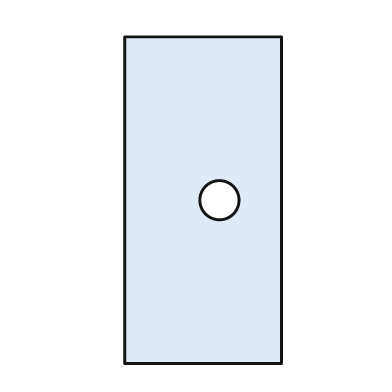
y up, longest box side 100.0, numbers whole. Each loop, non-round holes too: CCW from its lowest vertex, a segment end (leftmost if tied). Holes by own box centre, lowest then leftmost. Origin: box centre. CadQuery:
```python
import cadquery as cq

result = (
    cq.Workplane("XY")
    .moveTo(-24.0, -50.0)
    .lineTo(24.0, -50.0)
    .lineTo(24.0, 50.0)
    .lineTo(-24.0, 50.0)
    .close()
    .moveTo(5.0, 0.0)
    .circle(6.0)
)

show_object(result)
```